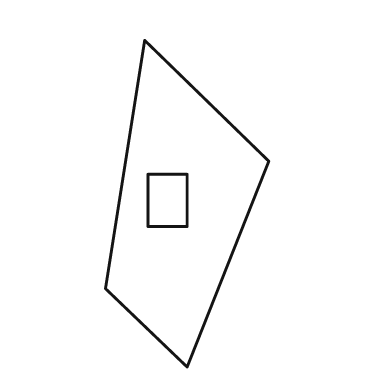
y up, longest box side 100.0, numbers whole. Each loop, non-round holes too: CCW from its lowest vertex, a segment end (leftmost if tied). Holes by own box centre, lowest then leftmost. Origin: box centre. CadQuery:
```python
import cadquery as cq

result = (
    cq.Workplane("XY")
    .moveTo(0.0, -50.0)
    .lineTo(25.0, 13.0)
    .lineTo(-13.0, 50.0)
    .lineTo(-25.0, -26.0)
    .close()
    .moveTo(-12.0, -7.0)
    .lineTo(0.0, -7.0)
    .lineTo(0.0, 9.0)
    .lineTo(-12.0, 9.0)
    .close()
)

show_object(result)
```